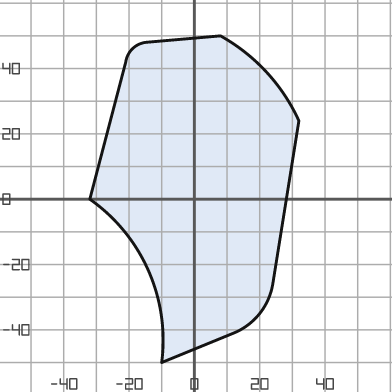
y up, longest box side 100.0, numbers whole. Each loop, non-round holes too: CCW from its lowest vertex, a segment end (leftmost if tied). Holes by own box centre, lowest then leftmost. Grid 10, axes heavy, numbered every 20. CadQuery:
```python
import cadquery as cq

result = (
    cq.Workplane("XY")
    .moveTo(-10.0, -50.0)
    .lineTo(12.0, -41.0)
    .threePointArc((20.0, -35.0), (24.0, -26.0))
    .lineTo(32.0, 24.0)
    .threePointArc((22.0, 39.0), (8.0, 50.0))
    .lineTo(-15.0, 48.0)
    .threePointArc((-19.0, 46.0), (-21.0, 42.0))
    .lineTo(-32.0, 0.0)
    .threePointArc((-14.0, -22.0), (-10.0, -50.0))
    .close()
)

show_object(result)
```